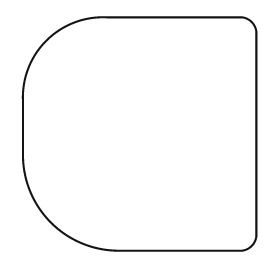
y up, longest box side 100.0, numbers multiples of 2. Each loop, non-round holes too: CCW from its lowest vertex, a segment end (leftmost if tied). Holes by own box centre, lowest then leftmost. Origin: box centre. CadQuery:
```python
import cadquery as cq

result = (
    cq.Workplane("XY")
    .moveTo(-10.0, -50.0)
    .lineTo(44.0, -50.0)
    .threePointArc((48.0, -48.0), (50.0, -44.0))
    .lineTo(50.0, 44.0)
    .threePointArc((48.0, 48.0), (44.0, 50.0))
    .lineTo(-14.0, 50.0)
    .threePointArc((-40.0, 40.0), (-50.0, 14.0))
    .lineTo(-50.0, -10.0)
    .threePointArc((-38.0, -38.0), (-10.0, -50.0))
    .close()
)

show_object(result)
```